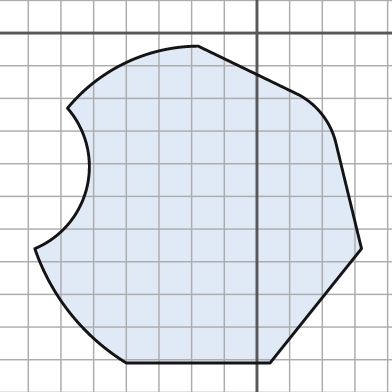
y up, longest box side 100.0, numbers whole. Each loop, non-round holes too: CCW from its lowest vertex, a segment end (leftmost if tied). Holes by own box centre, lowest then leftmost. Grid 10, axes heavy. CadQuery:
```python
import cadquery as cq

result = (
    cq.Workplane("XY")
    .moveTo(-40.0, -101.0)
    .lineTo(4.0, -101.0)
    .lineTo(32.0, -66.0)
    .lineTo(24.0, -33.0)
    .threePointArc((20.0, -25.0), (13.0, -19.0))
    .lineTo(-18.0, -4.0)
    .threePointArc((-40.0, -9.0), (-58.0, -23.0))
    .threePointArc((-52.0, -47.0), (-68.0, -66.0))
    .threePointArc((-57.0, -86.0), (-40.0, -101.0))
    .close()
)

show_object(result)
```